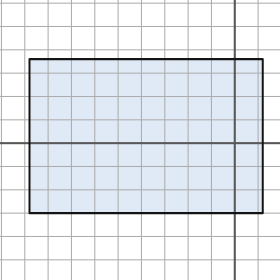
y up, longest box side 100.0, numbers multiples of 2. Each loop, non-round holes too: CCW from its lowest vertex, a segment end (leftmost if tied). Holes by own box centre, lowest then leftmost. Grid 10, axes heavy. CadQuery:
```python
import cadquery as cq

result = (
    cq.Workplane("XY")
    .moveTo(-88.0, -30.0)
    .lineTo(12.0, -30.0)
    .lineTo(12.0, 36.0)
    .lineTo(-88.0, 36.0)
    .close()
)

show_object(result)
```